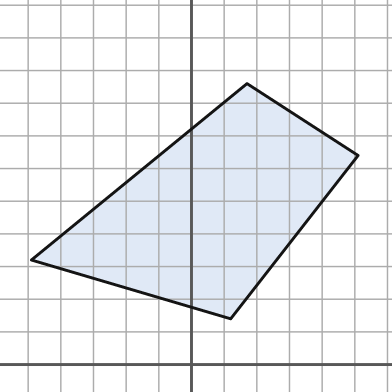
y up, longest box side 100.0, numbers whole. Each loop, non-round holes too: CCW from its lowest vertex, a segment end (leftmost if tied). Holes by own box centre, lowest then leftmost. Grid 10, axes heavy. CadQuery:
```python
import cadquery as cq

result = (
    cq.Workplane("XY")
    .moveTo(12.0, 14.0)
    .lineTo(51.0, 64.0)
    .lineTo(17.0, 86.0)
    .lineTo(-49.0, 32.0)
    .close()
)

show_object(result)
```